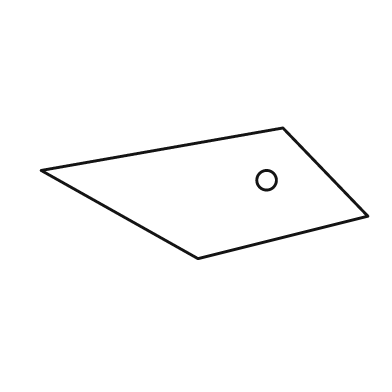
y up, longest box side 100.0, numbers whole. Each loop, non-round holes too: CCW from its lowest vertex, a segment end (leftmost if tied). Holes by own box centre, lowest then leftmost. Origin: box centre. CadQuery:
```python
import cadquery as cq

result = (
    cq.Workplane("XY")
    .moveTo(-2.0, -20.0)
    .lineTo(50.0, -7.0)
    .lineTo(24.0, 20.0)
    .lineTo(-50.0, 7.0)
    .close()
    .moveTo(19.0, 4.0)
    .circle(3.0)
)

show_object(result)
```